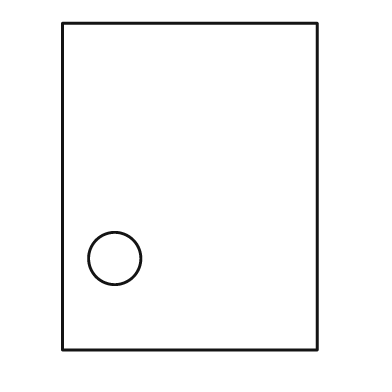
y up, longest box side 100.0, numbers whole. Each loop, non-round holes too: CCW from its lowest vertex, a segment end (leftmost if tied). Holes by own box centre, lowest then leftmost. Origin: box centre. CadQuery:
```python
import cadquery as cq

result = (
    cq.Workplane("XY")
    .moveTo(-39.0, -50.0)
    .lineTo(39.0, -50.0)
    .lineTo(39.0, 50.0)
    .lineTo(-39.0, 50.0)
    .close()
    .moveTo(-23.0, -22.0)
    .circle(8.0)
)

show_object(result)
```